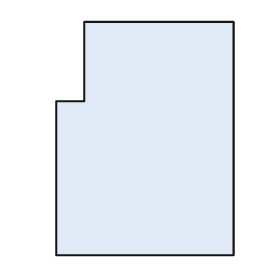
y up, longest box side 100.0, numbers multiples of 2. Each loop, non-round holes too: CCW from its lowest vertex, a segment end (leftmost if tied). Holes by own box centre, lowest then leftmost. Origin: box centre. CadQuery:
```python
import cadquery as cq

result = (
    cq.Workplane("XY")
    .moveTo(-38.0, -50.0)
    .lineTo(38.0, -50.0)
    .lineTo(38.0, 50.0)
    .lineTo(-26.0, 50.0)
    .lineTo(-26.0, 16.0)
    .lineTo(-38.0, 16.0)
    .close()
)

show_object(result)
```